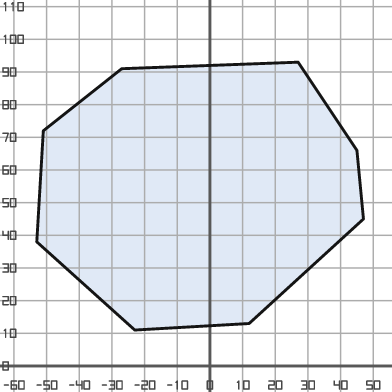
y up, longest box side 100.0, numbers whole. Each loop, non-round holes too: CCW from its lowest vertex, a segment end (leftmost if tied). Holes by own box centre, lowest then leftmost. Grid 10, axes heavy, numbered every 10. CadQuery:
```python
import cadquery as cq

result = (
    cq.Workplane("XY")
    .moveTo(-23.0, 11.0)
    .lineTo(12.0, 13.0)
    .lineTo(47.0, 45.0)
    .lineTo(45.0, 66.0)
    .lineTo(27.0, 93.0)
    .lineTo(-27.0, 91.0)
    .lineTo(-51.0, 72.0)
    .lineTo(-53.0, 38.0)
    .close()
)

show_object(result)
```